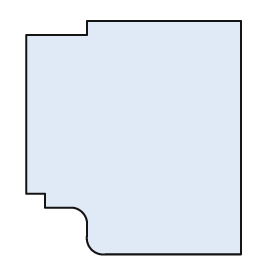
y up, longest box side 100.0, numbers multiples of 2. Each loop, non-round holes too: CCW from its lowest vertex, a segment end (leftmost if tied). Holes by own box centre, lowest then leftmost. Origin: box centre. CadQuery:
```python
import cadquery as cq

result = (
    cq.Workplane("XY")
    .moveTo(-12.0, -50.0)
    .lineTo(46.0, -50.0)
    .lineTo(46.0, 50.0)
    .lineTo(-20.0, 50.0)
    .lineTo(-20.0, 44.0)
    .lineTo(-46.0, 44.0)
    .lineTo(-46.0, -24.0)
    .lineTo(-38.0, -24.0)
    .lineTo(-38.0, -30.0)
    .lineTo(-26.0, -30.0)
    .threePointArc((-22.0, -32.0), (-20.0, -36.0))
    .lineTo(-20.0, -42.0)
    .threePointArc((-18.0, -48.0), (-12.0, -50.0))
    .close()
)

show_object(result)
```